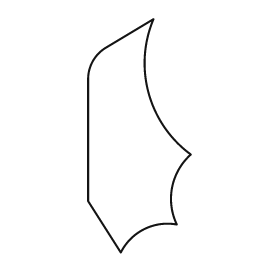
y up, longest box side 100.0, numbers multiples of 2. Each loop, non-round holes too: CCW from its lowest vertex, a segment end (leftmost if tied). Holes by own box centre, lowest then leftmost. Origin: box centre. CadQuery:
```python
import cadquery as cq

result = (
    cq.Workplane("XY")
    .moveTo(-8.0, -50.0)
    .threePointArc((2.0, -40.0), (16.0, -38.0))
    .threePointArc((14.0, -22.0), (22.0, -8.0))
    .threePointArc((4.0, 18.0), (6.0, 50.0))
    .lineTo(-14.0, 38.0)
    .threePointArc((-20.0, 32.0), (-22.0, 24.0))
    .lineTo(-22.0, -28.0)
    .close()
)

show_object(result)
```